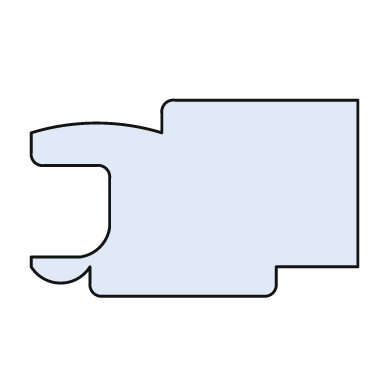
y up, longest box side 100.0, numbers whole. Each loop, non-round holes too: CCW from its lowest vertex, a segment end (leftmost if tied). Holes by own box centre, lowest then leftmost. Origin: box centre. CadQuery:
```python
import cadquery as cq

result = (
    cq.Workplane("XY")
    .moveTo(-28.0, -30.0)
    .lineTo(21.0, -30.0)
    .threePointArc((24.0, -29.0), (25.0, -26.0))
    .lineTo(25.0, -21.0)
    .lineTo(50.0, -21.0)
    .lineTo(50.0, 30.0)
    .lineTo(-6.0, 30.0)
    .threePointArc((-9.0, 29.0), (-10.0, 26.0))
    .lineTo(-10.0, 20.0)
    .threePointArc((-30.0, 23.0), (-50.0, 20.0))
    .lineTo(-50.0, 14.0)
    .threePointArc((-49.0, 11.0), (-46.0, 10.0))
    .lineTo(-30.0, 10.0)
    .threePointArc((-27.0, 9.0), (-26.0, 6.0))
    .lineTo(-26.0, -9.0)
    .threePointArc((-29.0, -15.0), (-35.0, -18.0))
    .lineTo(-50.0, -18.0)
    .lineTo(-50.0, -21.0)
    .threePointArc((-41.0, -26.0), (-32.0, -21.0))
    .lineTo(-32.0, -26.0)
    .threePointArc((-31.0, -29.0), (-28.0, -30.0))
    .close()
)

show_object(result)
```